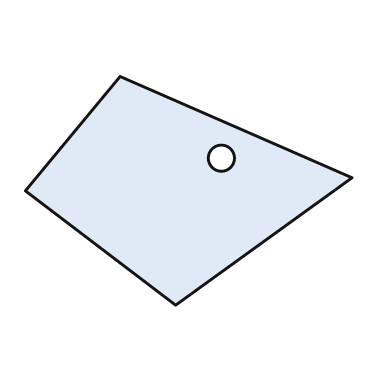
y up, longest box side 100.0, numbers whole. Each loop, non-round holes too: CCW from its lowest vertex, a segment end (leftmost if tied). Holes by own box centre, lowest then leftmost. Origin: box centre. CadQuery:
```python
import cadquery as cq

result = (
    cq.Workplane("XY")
    .moveTo(-4.0, -35.0)
    .lineTo(50.0, 4.0)
    .lineTo(-21.0, 35.0)
    .lineTo(-50.0, 0.0)
    .close()
    .moveTo(10.0, 10.0)
    .circle(4.0)
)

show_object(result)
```